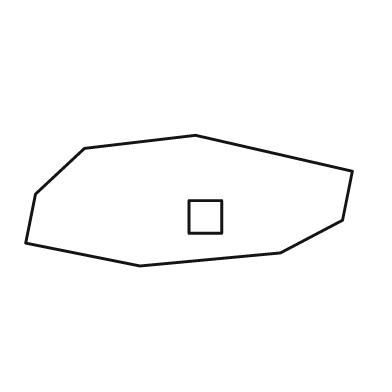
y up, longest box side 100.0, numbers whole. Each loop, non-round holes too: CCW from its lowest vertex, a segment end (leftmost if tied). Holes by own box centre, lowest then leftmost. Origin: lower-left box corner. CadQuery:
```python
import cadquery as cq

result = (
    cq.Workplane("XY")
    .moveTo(35.0, 0.0)
    .lineTo(78.0, 4.0)
    .lineTo(97.0, 14.0)
    .lineTo(100.0, 29.0)
    .lineTo(52.0, 40.0)
    .lineTo(18.0, 36.0)
    .lineTo(3.0, 22.0)
    .lineTo(0.0, 7.0)
    .close()
    .moveTo(50.0, 10.0)
    .lineTo(60.0, 10.0)
    .lineTo(60.0, 20.0)
    .lineTo(50.0, 20.0)
    .close()
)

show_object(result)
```